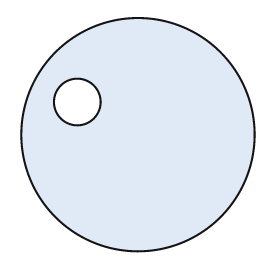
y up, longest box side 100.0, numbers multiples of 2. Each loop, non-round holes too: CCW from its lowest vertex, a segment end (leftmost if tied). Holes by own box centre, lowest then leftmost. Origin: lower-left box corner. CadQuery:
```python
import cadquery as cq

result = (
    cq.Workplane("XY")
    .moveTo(50.0, 50.0)
    .circle(50.0)
    .moveTo(24.0, 64.0)
    .circle(10.0)
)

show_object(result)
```